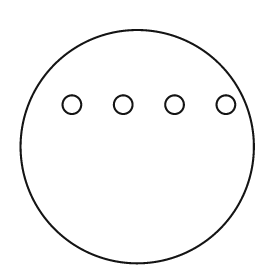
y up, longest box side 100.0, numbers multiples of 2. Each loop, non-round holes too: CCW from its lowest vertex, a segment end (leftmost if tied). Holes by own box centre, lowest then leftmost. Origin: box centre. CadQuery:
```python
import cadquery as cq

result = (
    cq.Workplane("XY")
    .moveTo(0.0, 0.0)
    .circle(50.0)
    .moveTo(-28.0, 18.0)
    .circle(4.0)
    .moveTo(-6.0, 18.0)
    .circle(4.0)
    .moveTo(16.0, 18.0)
    .circle(4.0)
    .moveTo(38.0, 18.0)
    .circle(4.0)
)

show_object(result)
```